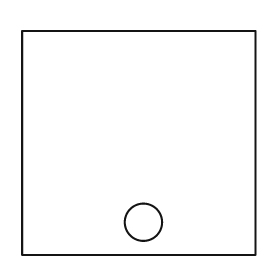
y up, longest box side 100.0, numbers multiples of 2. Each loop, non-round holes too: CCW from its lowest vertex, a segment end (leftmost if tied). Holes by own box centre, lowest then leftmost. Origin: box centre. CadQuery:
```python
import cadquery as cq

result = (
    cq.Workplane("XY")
    .moveTo(-50.0, -48.0)
    .lineTo(50.0, -48.0)
    .lineTo(50.0, 48.0)
    .lineTo(-50.0, 48.0)
    .close()
    .moveTo(2.0, -34.0)
    .circle(8.0)
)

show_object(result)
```